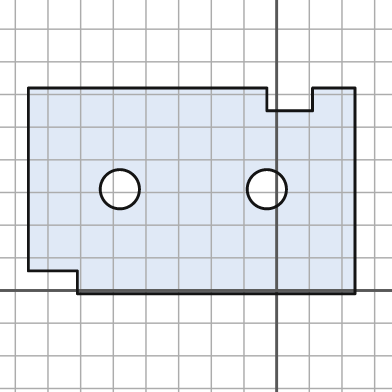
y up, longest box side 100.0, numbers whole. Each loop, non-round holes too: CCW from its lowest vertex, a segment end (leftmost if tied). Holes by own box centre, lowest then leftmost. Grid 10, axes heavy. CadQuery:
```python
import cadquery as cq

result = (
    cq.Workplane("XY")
    .moveTo(-61.0, -1.0)
    .lineTo(24.0, -1.0)
    .lineTo(24.0, 62.0)
    .lineTo(11.0, 62.0)
    .lineTo(11.0, 55.0)
    .lineTo(-3.0, 55.0)
    .lineTo(-3.0, 62.0)
    .lineTo(-76.0, 62.0)
    .lineTo(-76.0, 6.0)
    .lineTo(-61.0, 6.0)
    .close()
    .moveTo(-48.0, 31.0)
    .circle(6.0)
    .moveTo(-3.0, 31.0)
    .circle(6.0)
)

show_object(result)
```